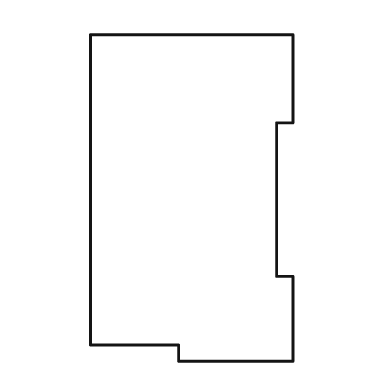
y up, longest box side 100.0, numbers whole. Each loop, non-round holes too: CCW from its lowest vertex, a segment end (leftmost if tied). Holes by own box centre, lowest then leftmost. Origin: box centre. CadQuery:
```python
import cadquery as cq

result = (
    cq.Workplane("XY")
    .moveTo(-4.0, -50.0)
    .lineTo(31.0, -50.0)
    .lineTo(31.0, -24.0)
    .lineTo(26.0, -24.0)
    .lineTo(26.0, 23.0)
    .lineTo(31.0, 23.0)
    .lineTo(31.0, 50.0)
    .lineTo(-31.0, 50.0)
    .lineTo(-31.0, -45.0)
    .lineTo(-4.0, -45.0)
    .close()
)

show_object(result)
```